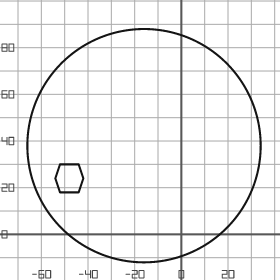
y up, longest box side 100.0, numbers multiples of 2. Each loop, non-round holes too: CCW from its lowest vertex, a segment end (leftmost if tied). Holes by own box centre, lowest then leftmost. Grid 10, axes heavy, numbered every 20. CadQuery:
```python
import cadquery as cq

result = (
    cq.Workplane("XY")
    .moveTo(-16.0, 38.0)
    .circle(50.0)
    .moveTo(-52.0, 18.0)
    .lineTo(-44.0, 18.0)
    .lineTo(-42.0, 24.0)
    .lineTo(-44.0, 30.0)
    .lineTo(-52.0, 30.0)
    .lineTo(-54.0, 24.0)
    .close()
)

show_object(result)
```